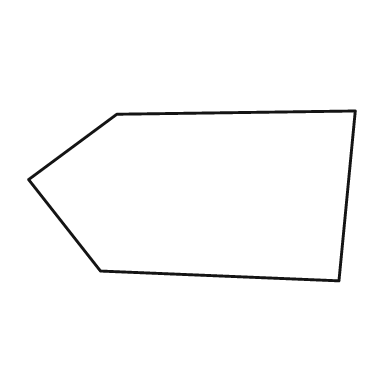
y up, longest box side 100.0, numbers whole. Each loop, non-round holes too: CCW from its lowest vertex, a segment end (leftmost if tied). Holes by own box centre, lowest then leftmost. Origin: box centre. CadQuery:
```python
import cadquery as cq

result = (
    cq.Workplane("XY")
    .moveTo(45.0, -26.0)
    .lineTo(50.0, 26.0)
    .lineTo(-23.0, 25.0)
    .lineTo(-50.0, 5.0)
    .lineTo(-28.0, -23.0)
    .close()
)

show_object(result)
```